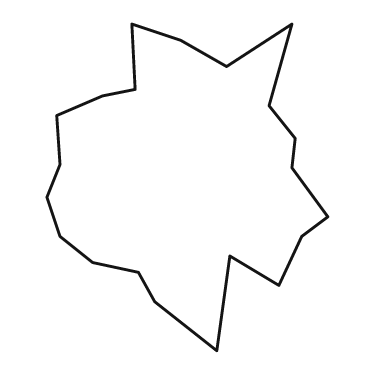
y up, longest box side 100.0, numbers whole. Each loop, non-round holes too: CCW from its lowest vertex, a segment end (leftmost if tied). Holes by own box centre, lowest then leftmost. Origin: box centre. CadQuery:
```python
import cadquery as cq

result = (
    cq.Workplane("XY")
    .moveTo(9.0, -50.0)
    .lineTo(13.0, -21.0)
    .lineTo(28.0, -30.0)
    .lineTo(35.0, -15.0)
    .lineTo(43.0, -9.0)
    .lineTo(32.0, 6.0)
    .lineTo(33.0, 15.0)
    .lineTo(25.0, 25.0)
    .lineTo(32.0, 50.0)
    .lineTo(12.0, 37.0)
    .lineTo(-2.0, 45.0)
    .lineTo(-17.0, 50.0)
    .lineTo(-16.0, 30.0)
    .lineTo(-26.0, 28.0)
    .lineTo(-40.0, 22.0)
    .lineTo(-39.0, 7.0)
    .lineTo(-43.0, -3.0)
    .lineTo(-39.0, -15.0)
    .lineTo(-29.0, -23.0)
    .lineTo(-15.0, -26.0)
    .lineTo(-10.0, -35.0)
    .close()
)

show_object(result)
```